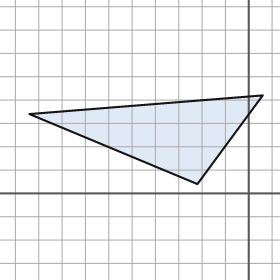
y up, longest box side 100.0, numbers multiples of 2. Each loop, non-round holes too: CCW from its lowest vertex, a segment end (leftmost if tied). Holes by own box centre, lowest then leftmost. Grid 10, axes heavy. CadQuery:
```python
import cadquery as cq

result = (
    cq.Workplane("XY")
    .moveTo(-22.0, 4.0)
    .lineTo(6.0, 42.0)
    .lineTo(-94.0, 34.0)
    .close()
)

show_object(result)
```